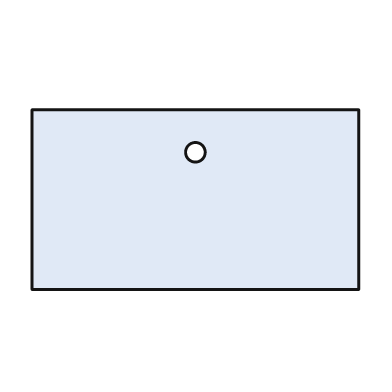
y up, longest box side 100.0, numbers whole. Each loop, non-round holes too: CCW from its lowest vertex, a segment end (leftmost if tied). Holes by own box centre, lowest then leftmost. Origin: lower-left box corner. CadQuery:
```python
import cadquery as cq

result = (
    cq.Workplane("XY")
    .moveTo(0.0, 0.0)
    .lineTo(100.0, 0.0)
    .lineTo(100.0, 55.0)
    .lineTo(0.0, 55.0)
    .close()
    .moveTo(50.0, 42.0)
    .circle(3.0)
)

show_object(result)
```